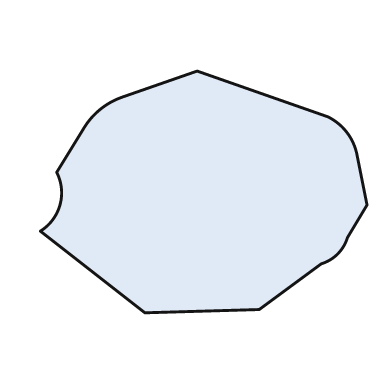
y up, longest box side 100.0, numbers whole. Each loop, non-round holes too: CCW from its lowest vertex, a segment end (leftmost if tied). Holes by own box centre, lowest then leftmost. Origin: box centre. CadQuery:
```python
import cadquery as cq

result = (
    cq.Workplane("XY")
    .moveTo(-18.0, -37.0)
    .lineTo(17.0, -36.0)
    .lineTo(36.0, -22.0)
    .threePointArc((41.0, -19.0), (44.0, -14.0))
    .lineTo(50.0, -4.0)
    .lineTo(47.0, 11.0)
    .threePointArc((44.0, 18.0), (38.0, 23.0))
    .lineTo(-2.0, 37.0)
    .lineTo(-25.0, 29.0)
    .threePointArc((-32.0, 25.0), (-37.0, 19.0))
    .lineTo(-45.0, 6.0)
    .threePointArc((-44.0, -4.0), (-50.0, -12.0))
    .close()
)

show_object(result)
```